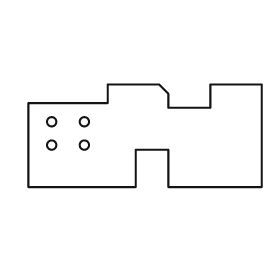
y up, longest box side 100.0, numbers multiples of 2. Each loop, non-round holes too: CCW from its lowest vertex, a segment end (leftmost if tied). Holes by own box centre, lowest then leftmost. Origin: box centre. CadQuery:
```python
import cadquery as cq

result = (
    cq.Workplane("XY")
    .moveTo(-50.0, -22.0)
    .lineTo(-4.0, -22.0)
    .lineTo(-4.0, -6.0)
    .lineTo(10.0, -6.0)
    .lineTo(10.0, -22.0)
    .lineTo(50.0, -22.0)
    .lineTo(50.0, 22.0)
    .lineTo(28.0, 22.0)
    .lineTo(28.0, 12.0)
    .lineTo(10.0, 12.0)
    .lineTo(10.0, 18.0)
    .lineTo(6.0, 22.0)
    .lineTo(-16.0, 22.0)
    .lineTo(-16.0, 14.0)
    .lineTo(-50.0, 14.0)
    .close()
    .moveTo(-40.0, -4.0)
    .circle(2.0)
    .moveTo(-26.0, -4.0)
    .circle(2.0)
    .moveTo(-40.0, 6.0)
    .circle(2.0)
    .moveTo(-26.0, 6.0)
    .circle(2.0)
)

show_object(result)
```